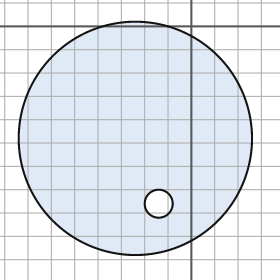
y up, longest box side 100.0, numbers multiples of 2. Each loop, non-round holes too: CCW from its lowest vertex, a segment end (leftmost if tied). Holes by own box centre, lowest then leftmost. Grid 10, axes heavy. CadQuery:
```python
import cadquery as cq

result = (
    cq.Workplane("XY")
    .moveTo(-24.0, -48.0)
    .circle(50.0)
    .moveTo(-14.0, -76.0)
    .circle(6.0)
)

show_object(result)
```